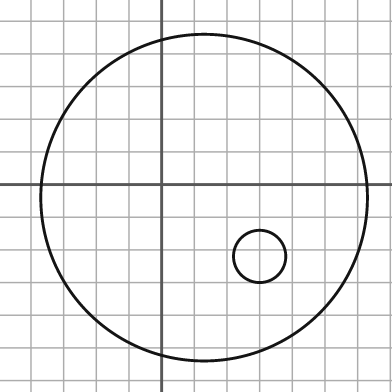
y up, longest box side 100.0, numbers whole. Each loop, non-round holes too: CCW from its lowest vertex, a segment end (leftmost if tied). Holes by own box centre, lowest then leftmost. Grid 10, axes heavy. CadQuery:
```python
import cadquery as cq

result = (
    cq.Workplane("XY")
    .moveTo(13.0, -4.0)
    .circle(50.0)
    .moveTo(30.0, -22.0)
    .circle(8.0)
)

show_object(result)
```